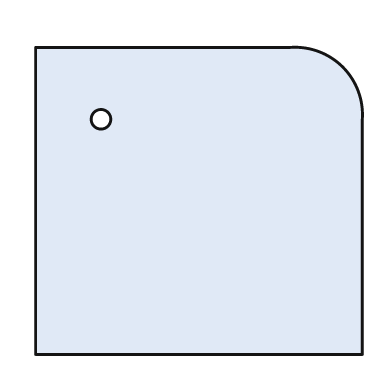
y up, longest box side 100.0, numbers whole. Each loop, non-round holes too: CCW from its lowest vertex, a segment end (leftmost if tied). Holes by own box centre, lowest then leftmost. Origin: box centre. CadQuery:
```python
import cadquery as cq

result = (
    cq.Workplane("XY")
    .moveTo(-50.0, -47.0)
    .lineTo(50.0, -47.0)
    .lineTo(50.0, 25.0)
    .threePointArc((44.0, 41.0), (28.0, 47.0))
    .lineTo(-50.0, 47.0)
    .close()
    .moveTo(-30.0, 25.0)
    .circle(3.0)
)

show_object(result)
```